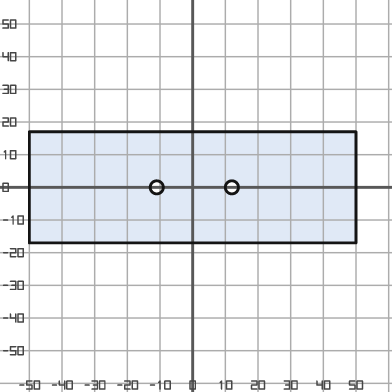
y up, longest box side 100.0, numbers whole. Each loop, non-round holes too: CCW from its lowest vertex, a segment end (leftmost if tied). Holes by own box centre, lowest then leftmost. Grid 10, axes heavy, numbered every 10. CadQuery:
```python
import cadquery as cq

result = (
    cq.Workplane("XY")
    .moveTo(-50.0, -17.0)
    .lineTo(50.0, -17.0)
    .lineTo(50.0, 17.0)
    .lineTo(-50.0, 17.0)
    .close()
    .moveTo(-11.0, 0.0)
    .circle(2.0)
    .moveTo(12.0, 0.0)
    .circle(2.0)
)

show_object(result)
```